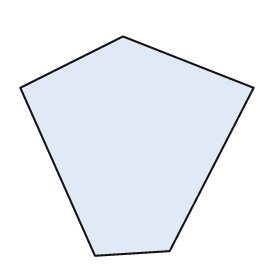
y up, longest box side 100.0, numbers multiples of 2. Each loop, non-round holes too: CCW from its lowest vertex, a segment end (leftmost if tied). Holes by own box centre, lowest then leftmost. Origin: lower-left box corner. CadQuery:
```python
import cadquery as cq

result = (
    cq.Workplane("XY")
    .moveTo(32.0, 0.0)
    .lineTo(64.0, 2.0)
    .lineTo(100.0, 72.0)
    .lineTo(44.0, 94.0)
    .lineTo(0.0, 72.0)
    .close()
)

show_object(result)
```